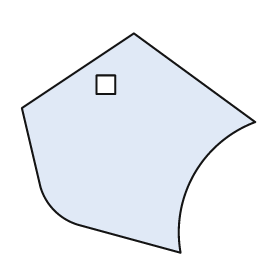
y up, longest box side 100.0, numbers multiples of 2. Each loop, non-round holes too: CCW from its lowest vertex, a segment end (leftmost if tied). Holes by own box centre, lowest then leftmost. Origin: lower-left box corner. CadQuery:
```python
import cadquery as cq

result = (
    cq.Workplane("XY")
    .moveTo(68.0, 0.0)
    .threePointArc((74.0, 34.0), (100.0, 56.0))
    .lineTo(48.0, 94.0)
    .lineTo(0.0, 62.0)
    .lineTo(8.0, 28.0)
    .threePointArc((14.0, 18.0), (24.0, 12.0))
    .close()
    .moveTo(32.0, 68.0)
    .lineTo(40.0, 68.0)
    .lineTo(40.0, 76.0)
    .lineTo(32.0, 76.0)
    .close()
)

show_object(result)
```